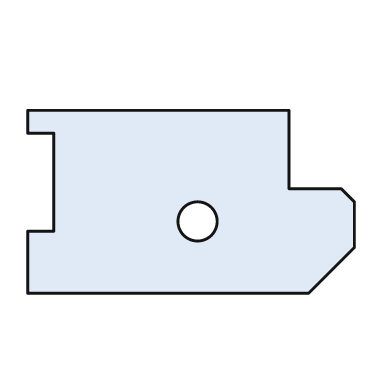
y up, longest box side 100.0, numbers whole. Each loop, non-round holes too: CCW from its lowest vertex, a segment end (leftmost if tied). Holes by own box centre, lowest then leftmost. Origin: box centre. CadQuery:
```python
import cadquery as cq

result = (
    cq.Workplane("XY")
    .moveTo(-50.0, -28.0)
    .lineTo(36.0, -28.0)
    .lineTo(50.0, -14.0)
    .lineTo(50.0, 0.0)
    .lineTo(46.0, 4.0)
    .lineTo(30.0, 4.0)
    .lineTo(30.0, 28.0)
    .lineTo(-50.0, 28.0)
    .lineTo(-50.0, 21.0)
    .lineTo(-42.0, 21.0)
    .lineTo(-42.0, -9.0)
    .lineTo(-50.0, -9.0)
    .close()
    .moveTo(2.0, -6.0)
    .circle(6.0)
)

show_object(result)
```